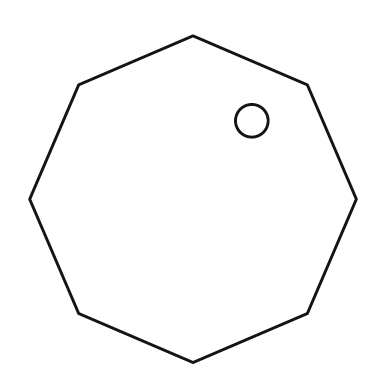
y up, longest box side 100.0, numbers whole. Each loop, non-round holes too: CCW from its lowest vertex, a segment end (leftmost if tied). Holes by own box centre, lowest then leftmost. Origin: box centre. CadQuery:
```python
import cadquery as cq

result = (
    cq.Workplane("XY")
    .moveTo(0.0, -50.0)
    .lineTo(35.0, -35.0)
    .lineTo(50.0, 0.0)
    .lineTo(35.0, 35.0)
    .lineTo(0.0, 50.0)
    .lineTo(-35.0, 35.0)
    .lineTo(-50.0, 0.0)
    .lineTo(-35.0, -35.0)
    .close()
    .moveTo(18.0, 24.0)
    .circle(5.0)
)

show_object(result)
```